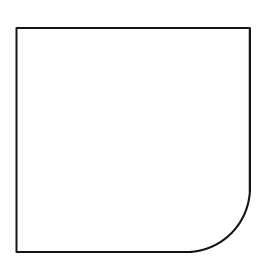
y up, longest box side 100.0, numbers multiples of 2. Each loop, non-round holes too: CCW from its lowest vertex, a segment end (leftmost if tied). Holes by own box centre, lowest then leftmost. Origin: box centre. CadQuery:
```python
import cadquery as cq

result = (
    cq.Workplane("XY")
    .moveTo(-50.0, -48.0)
    .lineTo(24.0, -48.0)
    .threePointArc((42.0, -40.0), (50.0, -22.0))
    .lineTo(50.0, 48.0)
    .lineTo(-50.0, 48.0)
    .close()
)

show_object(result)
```